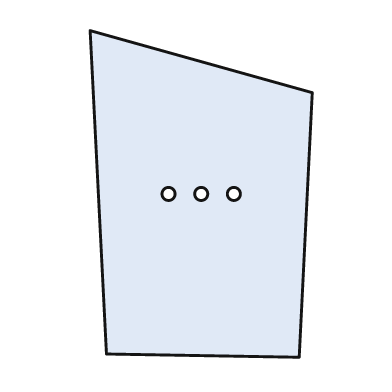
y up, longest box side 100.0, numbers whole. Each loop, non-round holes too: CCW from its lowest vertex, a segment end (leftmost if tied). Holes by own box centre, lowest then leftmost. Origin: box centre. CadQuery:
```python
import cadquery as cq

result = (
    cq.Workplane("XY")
    .moveTo(30.0, -50.0)
    .lineTo(34.0, 31.0)
    .lineTo(-34.0, 50.0)
    .lineTo(-29.0, -49.0)
    .close()
    .moveTo(-10.0, 0.0)
    .circle(2.0)
    .moveTo(0.0, 0.0)
    .circle(2.0)
    .moveTo(10.0, 0.0)
    .circle(2.0)
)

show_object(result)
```